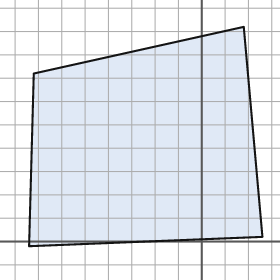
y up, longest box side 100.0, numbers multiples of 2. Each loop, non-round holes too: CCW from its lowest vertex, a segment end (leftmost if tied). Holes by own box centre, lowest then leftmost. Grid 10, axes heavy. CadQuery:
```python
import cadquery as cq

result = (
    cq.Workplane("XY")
    .moveTo(-74.0, -2.0)
    .lineTo(26.0, 2.0)
    .lineTo(18.0, 92.0)
    .lineTo(-72.0, 72.0)
    .close()
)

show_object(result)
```